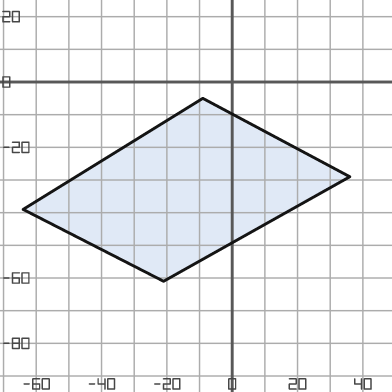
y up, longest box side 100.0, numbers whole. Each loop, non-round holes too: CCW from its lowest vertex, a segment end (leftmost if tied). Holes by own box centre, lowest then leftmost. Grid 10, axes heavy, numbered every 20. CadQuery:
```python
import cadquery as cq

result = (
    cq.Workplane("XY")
    .moveTo(-21.0, -61.0)
    .lineTo(36.0, -29.0)
    .lineTo(-9.0, -5.0)
    .lineTo(-64.0, -39.0)
    .close()
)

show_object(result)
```